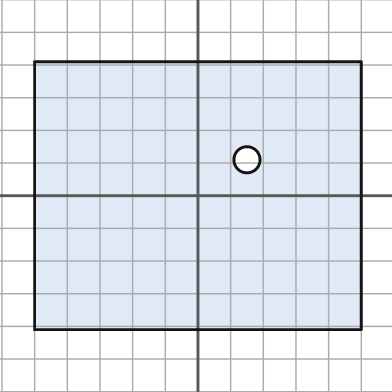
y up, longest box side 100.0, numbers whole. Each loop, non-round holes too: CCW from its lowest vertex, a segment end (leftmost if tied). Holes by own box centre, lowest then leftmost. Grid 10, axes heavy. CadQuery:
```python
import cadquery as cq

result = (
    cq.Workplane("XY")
    .moveTo(-50.0, -41.0)
    .lineTo(50.0, -41.0)
    .lineTo(50.0, 41.0)
    .lineTo(-50.0, 41.0)
    .close()
    .moveTo(15.0, 11.0)
    .circle(4.0)
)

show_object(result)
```